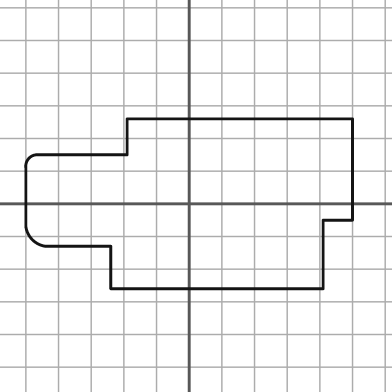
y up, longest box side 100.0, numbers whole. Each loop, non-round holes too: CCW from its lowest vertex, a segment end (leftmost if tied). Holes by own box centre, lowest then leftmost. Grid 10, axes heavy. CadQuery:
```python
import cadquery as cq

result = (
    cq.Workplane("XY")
    .moveTo(-24.0, -26.0)
    .lineTo(41.0, -26.0)
    .lineTo(41.0, -5.0)
    .lineTo(50.0, -5.0)
    .lineTo(50.0, 26.0)
    .lineTo(-19.0, 26.0)
    .lineTo(-19.0, 15.0)
    .lineTo(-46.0, 15.0)
    .threePointArc((-49.0, 14.0), (-50.0, 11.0))
    .lineTo(-50.0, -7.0)
    .threePointArc((-48.0, -11.0), (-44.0, -13.0))
    .lineTo(-24.0, -13.0)
    .close()
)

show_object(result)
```